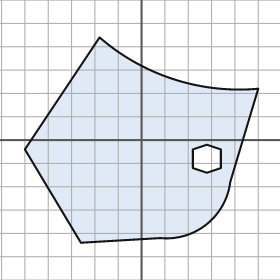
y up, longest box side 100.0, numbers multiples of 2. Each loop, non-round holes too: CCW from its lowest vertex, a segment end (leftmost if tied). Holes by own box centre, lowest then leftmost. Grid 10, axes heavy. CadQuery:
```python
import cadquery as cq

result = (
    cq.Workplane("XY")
    .moveTo(-26.0, -44.0)
    .lineTo(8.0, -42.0)
    .threePointArc((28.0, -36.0), (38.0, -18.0))
    .lineTo(50.0, 22.0)
    .threePointArc((14.0, 26.0), (-18.0, 44.0))
    .lineTo(-50.0, -4.0)
    .close()
    .moveTo(28.0, -14.0)
    .lineTo(34.0, -12.0)
    .lineTo(34.0, -4.0)
    .lineTo(28.0, -2.0)
    .lineTo(22.0, -4.0)
    .lineTo(22.0, -12.0)
    .close()
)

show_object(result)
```